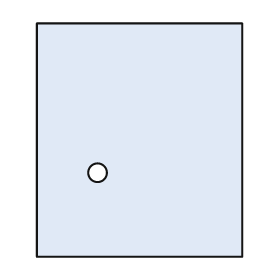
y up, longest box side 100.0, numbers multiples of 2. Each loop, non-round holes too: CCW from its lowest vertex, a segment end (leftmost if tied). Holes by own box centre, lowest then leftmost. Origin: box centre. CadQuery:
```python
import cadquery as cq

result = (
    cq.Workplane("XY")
    .moveTo(-44.0, -50.0)
    .lineTo(44.0, -50.0)
    .lineTo(44.0, 50.0)
    .lineTo(-44.0, 50.0)
    .close()
    .moveTo(-18.0, -14.0)
    .circle(4.0)
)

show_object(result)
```